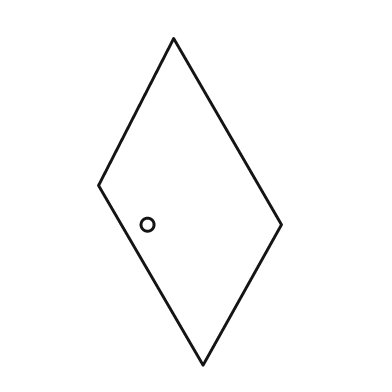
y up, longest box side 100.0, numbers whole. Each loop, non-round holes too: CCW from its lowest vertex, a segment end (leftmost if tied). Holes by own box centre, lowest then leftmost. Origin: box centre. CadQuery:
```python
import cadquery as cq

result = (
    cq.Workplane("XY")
    .moveTo(4.0, -50.0)
    .lineTo(28.0, -7.0)
    .lineTo(-5.0, 50.0)
    .lineTo(-28.0, 5.0)
    .close()
    .moveTo(-13.0, -7.0)
    .circle(2.0)
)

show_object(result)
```